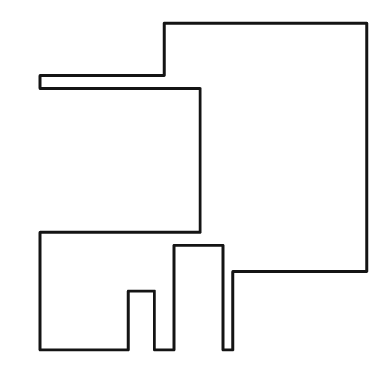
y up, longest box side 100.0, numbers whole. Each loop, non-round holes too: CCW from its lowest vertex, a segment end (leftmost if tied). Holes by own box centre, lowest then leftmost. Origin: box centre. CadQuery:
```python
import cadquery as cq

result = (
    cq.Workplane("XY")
    .moveTo(-50.0, -50.0)
    .lineTo(-23.0, -50.0)
    .lineTo(-23.0, -32.0)
    .lineTo(-15.0, -32.0)
    .lineTo(-15.0, -50.0)
    .lineTo(-9.0, -50.0)
    .lineTo(-9.0, -18.0)
    .lineTo(6.0, -18.0)
    .lineTo(6.0, -50.0)
    .lineTo(9.0, -50.0)
    .lineTo(9.0, -26.0)
    .lineTo(50.0, -26.0)
    .lineTo(50.0, 50.0)
    .lineTo(-12.0, 50.0)
    .lineTo(-12.0, 34.0)
    .lineTo(-50.0, 34.0)
    .lineTo(-50.0, 30.0)
    .lineTo(-1.0, 30.0)
    .lineTo(-1.0, -14.0)
    .lineTo(-50.0, -14.0)
    .close()
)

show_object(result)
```